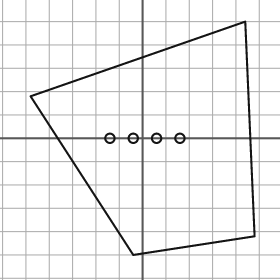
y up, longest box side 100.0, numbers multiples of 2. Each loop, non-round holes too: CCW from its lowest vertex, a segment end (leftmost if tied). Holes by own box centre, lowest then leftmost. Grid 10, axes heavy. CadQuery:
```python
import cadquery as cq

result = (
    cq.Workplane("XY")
    .moveTo(-4.0, -50.0)
    .lineTo(48.0, -42.0)
    .lineTo(44.0, 50.0)
    .lineTo(-48.0, 18.0)
    .close()
    .moveTo(-14.0, 0.0)
    .circle(2.0)
    .moveTo(-4.0, 0.0)
    .circle(2.0)
    .moveTo(6.0, 0.0)
    .circle(2.0)
    .moveTo(16.0, 0.0)
    .circle(2.0)
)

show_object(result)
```